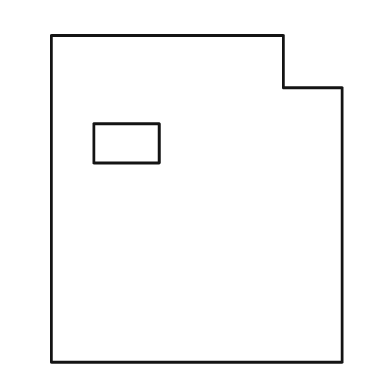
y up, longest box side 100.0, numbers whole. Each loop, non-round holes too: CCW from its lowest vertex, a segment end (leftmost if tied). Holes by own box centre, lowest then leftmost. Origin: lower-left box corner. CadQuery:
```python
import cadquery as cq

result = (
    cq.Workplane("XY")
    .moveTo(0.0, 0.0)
    .lineTo(89.0, 0.0)
    .lineTo(89.0, 84.0)
    .lineTo(71.0, 84.0)
    .lineTo(71.0, 100.0)
    .lineTo(0.0, 100.0)
    .close()
    .moveTo(13.0, 61.0)
    .lineTo(33.0, 61.0)
    .lineTo(33.0, 73.0)
    .lineTo(13.0, 73.0)
    .close()
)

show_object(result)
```